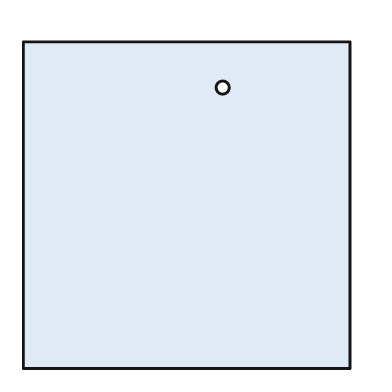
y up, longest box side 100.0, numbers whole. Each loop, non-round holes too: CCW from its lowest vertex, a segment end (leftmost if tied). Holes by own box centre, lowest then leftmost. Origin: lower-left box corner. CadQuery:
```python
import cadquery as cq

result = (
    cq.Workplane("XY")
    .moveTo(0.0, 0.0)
    .lineTo(100.0, 0.0)
    .lineTo(100.0, 100.0)
    .lineTo(0.0, 100.0)
    .close()
    .moveTo(61.0, 86.0)
    .circle(2.0)
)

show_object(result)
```